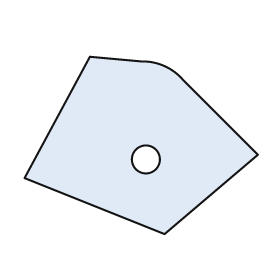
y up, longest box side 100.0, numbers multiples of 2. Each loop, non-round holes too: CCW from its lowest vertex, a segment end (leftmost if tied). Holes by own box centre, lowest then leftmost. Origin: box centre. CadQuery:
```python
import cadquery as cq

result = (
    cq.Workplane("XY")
    .moveTo(10.0, -38.0)
    .lineTo(50.0, -4.0)
    .lineTo(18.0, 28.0)
    .threePointArc((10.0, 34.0), (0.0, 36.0))
    .lineTo(-22.0, 38.0)
    .lineTo(-50.0, -14.0)
    .close()
    .moveTo(2.0, -6.0)
    .circle(6.0)
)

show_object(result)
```